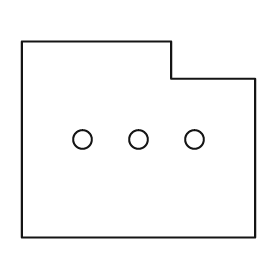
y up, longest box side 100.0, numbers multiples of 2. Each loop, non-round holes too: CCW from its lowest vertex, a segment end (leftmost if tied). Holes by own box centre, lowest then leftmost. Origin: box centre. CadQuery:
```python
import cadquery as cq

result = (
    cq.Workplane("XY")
    .moveTo(-50.0, -42.0)
    .lineTo(50.0, -42.0)
    .lineTo(50.0, 26.0)
    .lineTo(14.0, 26.0)
    .lineTo(14.0, 42.0)
    .lineTo(-50.0, 42.0)
    .close()
    .moveTo(-24.0, 0.0)
    .circle(4.0)
    .moveTo(0.0, 0.0)
    .circle(4.0)
    .moveTo(24.0, 0.0)
    .circle(4.0)
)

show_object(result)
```